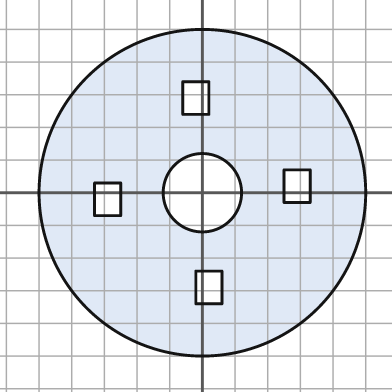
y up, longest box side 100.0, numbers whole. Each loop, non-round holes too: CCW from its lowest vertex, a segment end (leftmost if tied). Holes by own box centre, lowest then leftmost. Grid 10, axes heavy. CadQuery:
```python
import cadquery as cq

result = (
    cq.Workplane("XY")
    .moveTo(0.0, 0.0)
    .circle(50.0)
    .moveTo(-2.0, -34.0)
    .lineTo(6.0, -34.0)
    .lineTo(6.0, -24.0)
    .lineTo(-2.0, -24.0)
    .close()
    .moveTo(-33.0, -7.0)
    .lineTo(-25.0, -7.0)
    .lineTo(-25.0, 3.0)
    .lineTo(-33.0, 3.0)
    .close()
    .moveTo(0.0, 0.0)
    .circle(12.0)
    .moveTo(25.0, -3.0)
    .lineTo(33.0, -3.0)
    .lineTo(33.0, 7.0)
    .lineTo(25.0, 7.0)
    .close()
    .moveTo(-6.0, 24.0)
    .lineTo(2.0, 24.0)
    .lineTo(2.0, 34.0)
    .lineTo(-6.0, 34.0)
    .close()
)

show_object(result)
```